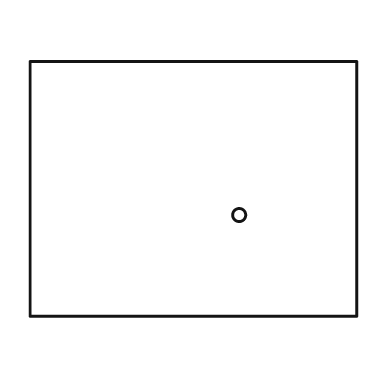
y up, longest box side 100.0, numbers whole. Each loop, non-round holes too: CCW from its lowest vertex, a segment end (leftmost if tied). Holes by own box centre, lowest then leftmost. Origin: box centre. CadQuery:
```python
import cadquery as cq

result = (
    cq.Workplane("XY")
    .moveTo(-50.0, -39.0)
    .lineTo(50.0, -39.0)
    .lineTo(50.0, 39.0)
    .lineTo(-50.0, 39.0)
    .close()
    .moveTo(14.0, -8.0)
    .circle(2.0)
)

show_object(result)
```